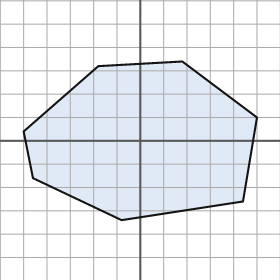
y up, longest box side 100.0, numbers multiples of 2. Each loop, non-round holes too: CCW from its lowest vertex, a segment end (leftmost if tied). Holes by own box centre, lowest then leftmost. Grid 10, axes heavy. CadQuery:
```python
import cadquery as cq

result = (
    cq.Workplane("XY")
    .moveTo(-8.0, -34.0)
    .lineTo(44.0, -26.0)
    .lineTo(50.0, 10.0)
    .lineTo(18.0, 34.0)
    .lineTo(-18.0, 32.0)
    .lineTo(-50.0, 4.0)
    .lineTo(-46.0, -16.0)
    .close()
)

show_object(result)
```